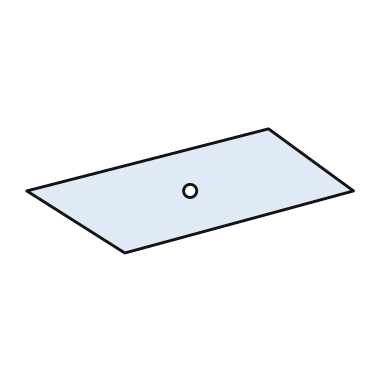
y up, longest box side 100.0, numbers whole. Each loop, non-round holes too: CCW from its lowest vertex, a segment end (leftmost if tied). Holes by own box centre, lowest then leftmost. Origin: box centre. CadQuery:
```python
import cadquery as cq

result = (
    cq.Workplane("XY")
    .moveTo(-20.0, -19.0)
    .lineTo(50.0, 0.0)
    .lineTo(24.0, 19.0)
    .lineTo(-50.0, 0.0)
    .close()
    .moveTo(0.0, 0.0)
    .circle(2.0)
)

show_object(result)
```